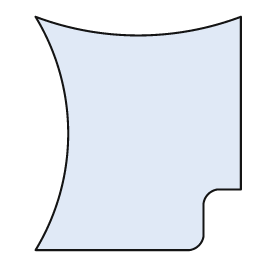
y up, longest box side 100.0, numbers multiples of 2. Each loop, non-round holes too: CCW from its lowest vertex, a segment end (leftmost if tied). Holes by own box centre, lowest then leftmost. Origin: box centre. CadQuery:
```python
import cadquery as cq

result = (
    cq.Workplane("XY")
    .moveTo(-44.0, -50.0)
    .lineTo(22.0, -50.0)
    .threePointArc((26.0, -48.0), (28.0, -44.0))
    .lineTo(28.0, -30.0)
    .threePointArc((30.0, -26.0), (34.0, -24.0))
    .lineTo(44.0, -24.0)
    .lineTo(44.0, 50.0)
    .threePointArc((0.0, 42.0), (-44.0, 50.0))
    .threePointArc((-30.0, 0.0), (-44.0, -50.0))
    .close()
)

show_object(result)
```